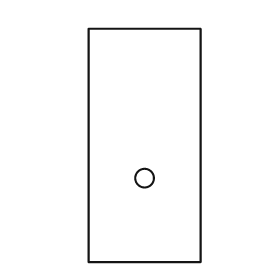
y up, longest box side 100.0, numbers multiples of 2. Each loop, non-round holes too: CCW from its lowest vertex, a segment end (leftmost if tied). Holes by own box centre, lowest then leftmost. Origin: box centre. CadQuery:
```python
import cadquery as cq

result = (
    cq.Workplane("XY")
    .moveTo(-24.0, -50.0)
    .lineTo(24.0, -50.0)
    .lineTo(24.0, 50.0)
    .lineTo(-24.0, 50.0)
    .close()
    .moveTo(0.0, -14.0)
    .circle(4.0)
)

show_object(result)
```